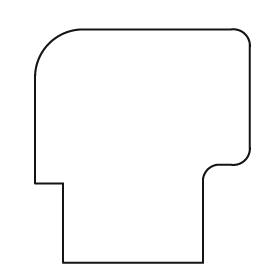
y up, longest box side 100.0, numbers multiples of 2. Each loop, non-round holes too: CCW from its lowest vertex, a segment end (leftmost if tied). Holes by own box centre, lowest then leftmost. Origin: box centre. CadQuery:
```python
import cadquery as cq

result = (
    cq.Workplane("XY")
    .moveTo(-34.0, -50.0)
    .lineTo(26.0, -50.0)
    .lineTo(26.0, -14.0)
    .threePointArc((28.0, -10.0), (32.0, -8.0))
    .lineTo(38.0, -8.0)
    .threePointArc((44.0, -6.0), (46.0, 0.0))
    .lineTo(46.0, 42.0)
    .threePointArc((44.0, 48.0), (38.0, 50.0))
    .lineTo(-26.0, 50.0)
    .threePointArc((-40.0, 44.0), (-46.0, 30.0))
    .lineTo(-46.0, -16.0)
    .lineTo(-34.0, -16.0)
    .close()
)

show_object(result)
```